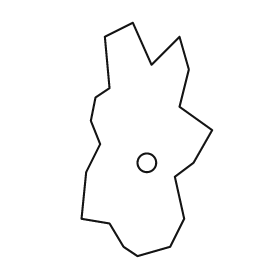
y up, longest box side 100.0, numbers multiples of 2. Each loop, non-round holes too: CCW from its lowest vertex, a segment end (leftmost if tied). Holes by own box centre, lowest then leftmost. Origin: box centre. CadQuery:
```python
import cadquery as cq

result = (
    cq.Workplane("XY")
    .moveTo(-4.0, -50.0)
    .lineTo(10.0, -46.0)
    .lineTo(16.0, -34.0)
    .lineTo(12.0, -16.0)
    .lineTo(20.0, -10.0)
    .lineTo(28.0, 4.0)
    .lineTo(14.0, 14.0)
    .lineTo(18.0, 30.0)
    .lineTo(14.0, 44.0)
    .lineTo(2.0, 32.0)
    .lineTo(-6.0, 50.0)
    .lineTo(-18.0, 44.0)
    .lineTo(-16.0, 22.0)
    .lineTo(-22.0, 18.0)
    .lineTo(-24.0, 8.0)
    .lineTo(-20.0, -2.0)
    .lineTo(-26.0, -14.0)
    .lineTo(-28.0, -34.0)
    .lineTo(-16.0, -36.0)
    .lineTo(-10.0, -46.0)
    .close()
    .moveTo(0.0, -10.0)
    .circle(4.0)
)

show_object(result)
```